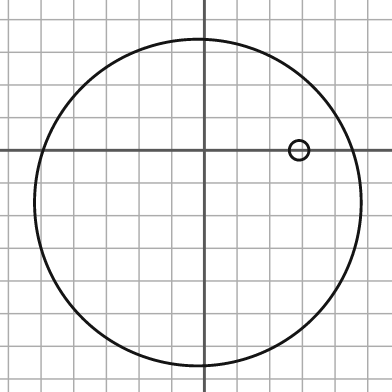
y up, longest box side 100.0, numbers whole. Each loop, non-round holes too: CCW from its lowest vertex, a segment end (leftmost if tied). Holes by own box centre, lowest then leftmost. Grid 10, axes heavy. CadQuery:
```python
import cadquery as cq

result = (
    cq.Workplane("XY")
    .moveTo(-2.0, -16.0)
    .circle(50.0)
    .moveTo(29.0, 0.0)
    .circle(3.0)
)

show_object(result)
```